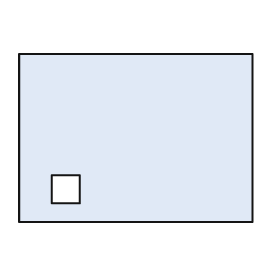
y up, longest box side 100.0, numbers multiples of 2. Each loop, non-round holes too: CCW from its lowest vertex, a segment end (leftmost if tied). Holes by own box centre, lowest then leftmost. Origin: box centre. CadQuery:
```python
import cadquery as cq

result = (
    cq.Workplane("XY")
    .moveTo(-50.0, -36.0)
    .lineTo(50.0, -36.0)
    .lineTo(50.0, 36.0)
    .lineTo(-50.0, 36.0)
    .close()
    .moveTo(-36.0, -28.0)
    .lineTo(-24.0, -28.0)
    .lineTo(-24.0, -16.0)
    .lineTo(-36.0, -16.0)
    .close()
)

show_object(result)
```